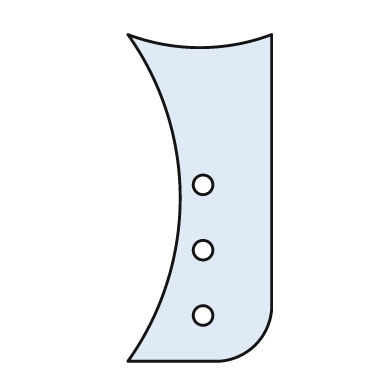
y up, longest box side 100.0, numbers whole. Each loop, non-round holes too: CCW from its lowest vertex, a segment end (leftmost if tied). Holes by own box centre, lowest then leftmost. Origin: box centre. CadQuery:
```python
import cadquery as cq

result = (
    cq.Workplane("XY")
    .moveTo(-22.0, -50.0)
    .lineTo(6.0, -50.0)
    .threePointArc((17.0, -45.0), (22.0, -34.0))
    .lineTo(22.0, 50.0)
    .threePointArc((0.0, 46.0), (-22.0, 50.0))
    .threePointArc((-6.0, 0.0), (-22.0, -50.0))
    .close()
    .moveTo(1.0, -36.0)
    .circle(3.0)
    .moveTo(1.0, -16.0)
    .circle(3.0)
    .moveTo(1.0, 4.0)
    .circle(3.0)
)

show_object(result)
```